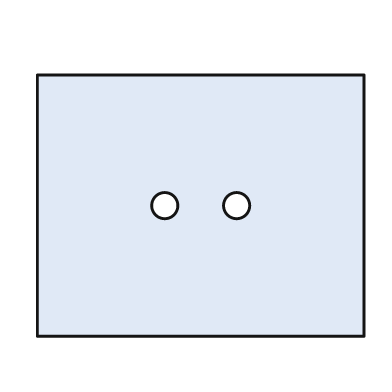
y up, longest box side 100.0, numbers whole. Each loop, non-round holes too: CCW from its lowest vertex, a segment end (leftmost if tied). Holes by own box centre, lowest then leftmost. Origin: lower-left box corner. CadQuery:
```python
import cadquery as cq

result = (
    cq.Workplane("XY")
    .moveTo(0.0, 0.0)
    .lineTo(100.0, 0.0)
    .lineTo(100.0, 80.0)
    .lineTo(0.0, 80.0)
    .close()
    .moveTo(39.0, 40.0)
    .circle(4.0)
    .moveTo(61.0, 40.0)
    .circle(4.0)
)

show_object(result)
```